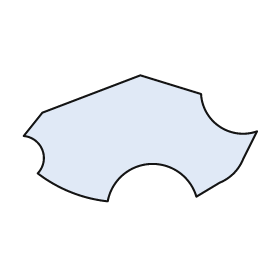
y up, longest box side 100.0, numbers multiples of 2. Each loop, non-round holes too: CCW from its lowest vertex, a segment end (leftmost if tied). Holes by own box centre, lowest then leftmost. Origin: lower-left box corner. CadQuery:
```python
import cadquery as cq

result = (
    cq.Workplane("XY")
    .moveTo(36.0, 0.0)
    .threePointArc((54.0, 16.0), (74.0, 2.0))
    .lineTo(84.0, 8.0)
    .threePointArc((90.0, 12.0), (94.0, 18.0))
    .lineTo(100.0, 30.0)
    .threePointArc((84.0, 32.0), (76.0, 46.0))
    .lineTo(50.0, 54.0)
    .lineTo(8.0, 38.0)
    .lineTo(0.0, 28.0)
    .threePointArc((8.0, 22.0), (6.0, 12.0))
    .threePointArc((20.0, 4.0), (36.0, 0.0))
    .close()
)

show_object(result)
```